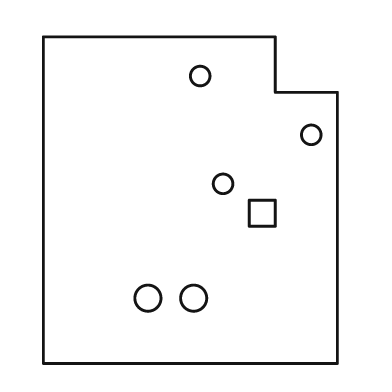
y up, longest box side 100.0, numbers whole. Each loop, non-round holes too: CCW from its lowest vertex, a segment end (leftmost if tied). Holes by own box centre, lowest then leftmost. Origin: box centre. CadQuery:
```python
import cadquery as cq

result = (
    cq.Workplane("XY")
    .moveTo(-45.0, -50.0)
    .lineTo(45.0, -50.0)
    .lineTo(45.0, 33.0)
    .lineTo(26.0, 33.0)
    .lineTo(26.0, 50.0)
    .lineTo(-45.0, 50.0)
    .close()
    .moveTo(-13.0, -30.0)
    .circle(4.0)
    .moveTo(1.0, -30.0)
    .circle(4.0)
    .moveTo(18.0, -8.0)
    .lineTo(26.0, -8.0)
    .lineTo(26.0, 0.0)
    .lineTo(18.0, 0.0)
    .close()
    .moveTo(10.0, 5.0)
    .circle(3.0)
    .moveTo(37.0, 20.0)
    .circle(3.0)
    .moveTo(3.0, 38.0)
    .circle(3.0)
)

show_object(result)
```